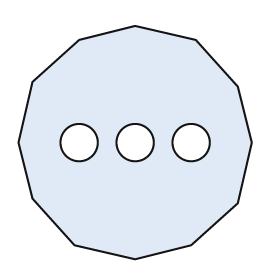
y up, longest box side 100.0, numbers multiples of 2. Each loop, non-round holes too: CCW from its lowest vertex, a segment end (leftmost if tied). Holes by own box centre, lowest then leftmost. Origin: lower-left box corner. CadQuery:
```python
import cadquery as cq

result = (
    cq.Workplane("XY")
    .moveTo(50.0, 0.0)
    .lineTo(74.0, 6.0)
    .lineTo(94.0, 24.0)
    .lineTo(100.0, 50.0)
    .lineTo(94.0, 74.0)
    .lineTo(76.0, 94.0)
    .lineTo(50.0, 100.0)
    .lineTo(26.0, 94.0)
    .lineTo(6.0, 76.0)
    .lineTo(0.0, 50.0)
    .lineTo(6.0, 26.0)
    .lineTo(24.0, 6.0)
    .close()
    .moveTo(26.0, 50.0)
    .circle(8.0)
    .moveTo(50.0, 50.0)
    .circle(8.0)
    .moveTo(74.0, 50.0)
    .circle(8.0)
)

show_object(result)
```